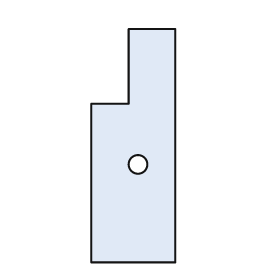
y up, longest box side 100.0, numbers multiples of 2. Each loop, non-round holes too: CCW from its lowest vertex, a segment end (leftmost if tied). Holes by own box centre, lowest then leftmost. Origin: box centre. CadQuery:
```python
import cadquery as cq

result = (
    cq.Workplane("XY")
    .moveTo(-18.0, -50.0)
    .lineTo(18.0, -50.0)
    .lineTo(18.0, 50.0)
    .lineTo(-2.0, 50.0)
    .lineTo(-2.0, 18.0)
    .lineTo(-18.0, 18.0)
    .close()
    .moveTo(2.0, -8.0)
    .circle(4.0)
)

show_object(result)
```